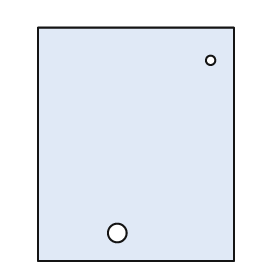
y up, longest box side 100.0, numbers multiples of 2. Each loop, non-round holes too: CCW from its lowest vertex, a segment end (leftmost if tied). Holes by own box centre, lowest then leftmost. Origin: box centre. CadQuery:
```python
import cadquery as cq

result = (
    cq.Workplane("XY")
    .moveTo(-42.0, -50.0)
    .lineTo(42.0, -50.0)
    .lineTo(42.0, 50.0)
    .lineTo(-42.0, 50.0)
    .close()
    .moveTo(-8.0, -38.0)
    .circle(4.0)
    .moveTo(32.0, 36.0)
    .circle(2.0)
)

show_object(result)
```